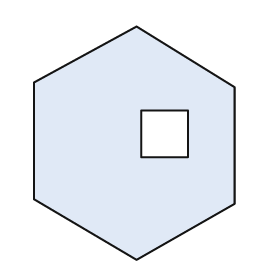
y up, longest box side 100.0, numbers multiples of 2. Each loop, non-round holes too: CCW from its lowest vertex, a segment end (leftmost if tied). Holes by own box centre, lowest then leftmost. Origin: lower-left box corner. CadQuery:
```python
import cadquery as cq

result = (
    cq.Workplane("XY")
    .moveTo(44.0, 0.0)
    .lineTo(86.0, 24.0)
    .lineTo(86.0, 74.0)
    .lineTo(44.0, 100.0)
    .lineTo(0.0, 76.0)
    .lineTo(0.0, 26.0)
    .close()
    .moveTo(46.0, 44.0)
    .lineTo(66.0, 44.0)
    .lineTo(66.0, 64.0)
    .lineTo(46.0, 64.0)
    .close()
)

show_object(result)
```